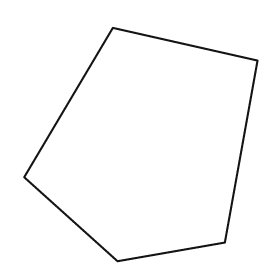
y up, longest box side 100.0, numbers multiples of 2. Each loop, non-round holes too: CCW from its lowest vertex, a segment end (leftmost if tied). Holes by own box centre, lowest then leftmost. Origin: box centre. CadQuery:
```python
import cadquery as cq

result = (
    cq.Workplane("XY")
    .moveTo(-10.0, -50.0)
    .lineTo(36.0, -42.0)
    .lineTo(50.0, 36.0)
    .lineTo(-12.0, 50.0)
    .lineTo(-50.0, -14.0)
    .close()
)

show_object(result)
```